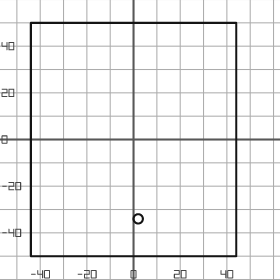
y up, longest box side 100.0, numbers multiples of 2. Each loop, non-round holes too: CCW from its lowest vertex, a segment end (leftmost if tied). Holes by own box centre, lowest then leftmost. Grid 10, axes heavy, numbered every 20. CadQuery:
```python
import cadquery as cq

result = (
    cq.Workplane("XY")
    .moveTo(-44.0, -50.0)
    .lineTo(44.0, -50.0)
    .lineTo(44.0, 50.0)
    .lineTo(-44.0, 50.0)
    .close()
    .moveTo(2.0, -34.0)
    .circle(2.0)
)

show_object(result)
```